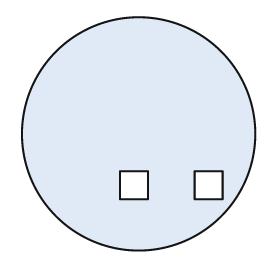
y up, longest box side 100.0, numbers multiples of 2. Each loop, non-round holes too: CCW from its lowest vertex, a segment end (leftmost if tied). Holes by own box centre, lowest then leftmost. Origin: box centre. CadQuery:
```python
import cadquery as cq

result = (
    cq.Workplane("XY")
    .moveTo(0.0, 0.0)
    .circle(50.0)
    .moveTo(-8.0, -28.0)
    .lineTo(4.0, -28.0)
    .lineTo(4.0, -16.0)
    .lineTo(-8.0, -16.0)
    .close()
    .moveTo(24.0, -28.0)
    .lineTo(36.0, -28.0)
    .lineTo(36.0, -16.0)
    .lineTo(24.0, -16.0)
    .close()
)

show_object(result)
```